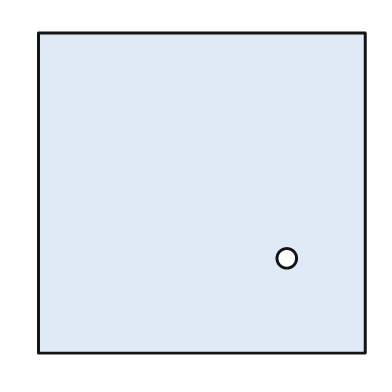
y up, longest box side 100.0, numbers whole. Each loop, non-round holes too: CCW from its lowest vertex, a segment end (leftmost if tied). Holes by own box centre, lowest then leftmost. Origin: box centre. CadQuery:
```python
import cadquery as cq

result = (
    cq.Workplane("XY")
    .moveTo(-50.0, -49.0)
    .lineTo(50.0, -49.0)
    .lineTo(50.0, 49.0)
    .lineTo(-50.0, 49.0)
    .close()
    .moveTo(26.0, -20.0)
    .circle(3.0)
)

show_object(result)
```